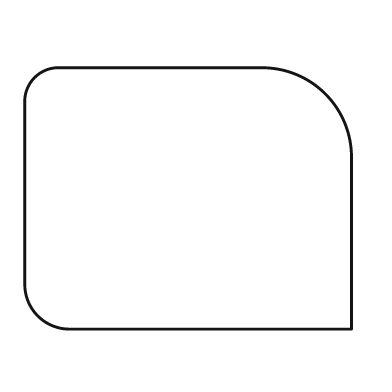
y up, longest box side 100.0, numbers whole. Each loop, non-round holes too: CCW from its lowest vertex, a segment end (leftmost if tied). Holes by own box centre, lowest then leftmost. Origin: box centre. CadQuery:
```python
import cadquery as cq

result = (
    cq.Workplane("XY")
    .moveTo(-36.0, -40.0)
    .lineTo(50.0, -40.0)
    .lineTo(50.0, 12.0)
    .threePointArc((42.0, 32.0), (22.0, 40.0))
    .lineTo(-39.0, 40.0)
    .threePointArc((-47.0, 37.0), (-50.0, 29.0))
    .lineTo(-50.0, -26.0)
    .threePointArc((-46.0, -36.0), (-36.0, -40.0))
    .close()
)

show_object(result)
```